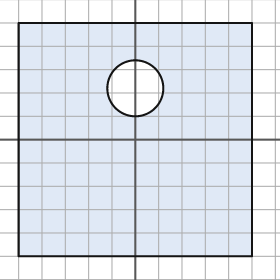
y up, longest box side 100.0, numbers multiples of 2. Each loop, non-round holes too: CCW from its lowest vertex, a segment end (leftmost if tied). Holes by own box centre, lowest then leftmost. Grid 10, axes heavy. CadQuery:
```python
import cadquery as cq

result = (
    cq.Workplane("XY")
    .moveTo(-50.0, -50.0)
    .lineTo(50.0, -50.0)
    .lineTo(50.0, 50.0)
    .lineTo(-50.0, 50.0)
    .close()
    .moveTo(0.0, 22.0)
    .circle(12.0)
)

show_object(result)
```